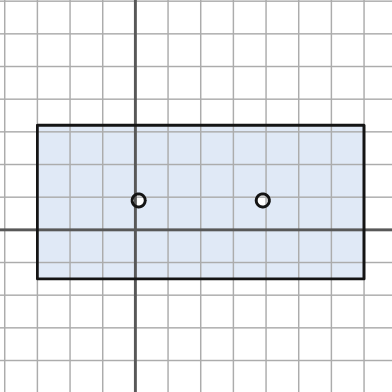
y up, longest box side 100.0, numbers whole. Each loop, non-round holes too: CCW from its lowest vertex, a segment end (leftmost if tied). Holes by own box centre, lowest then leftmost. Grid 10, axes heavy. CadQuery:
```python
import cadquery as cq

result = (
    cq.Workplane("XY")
    .moveTo(-30.0, -15.0)
    .lineTo(70.0, -15.0)
    .lineTo(70.0, 32.0)
    .lineTo(-30.0, 32.0)
    .close()
    .moveTo(1.0, 9.0)
    .circle(2.0)
    .moveTo(39.0, 9.0)
    .circle(2.0)
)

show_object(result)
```